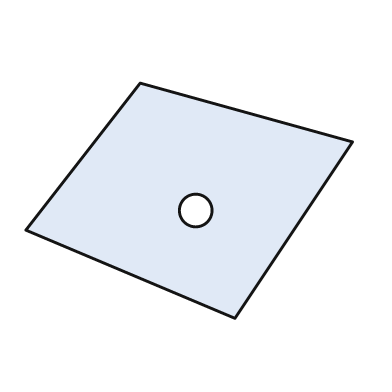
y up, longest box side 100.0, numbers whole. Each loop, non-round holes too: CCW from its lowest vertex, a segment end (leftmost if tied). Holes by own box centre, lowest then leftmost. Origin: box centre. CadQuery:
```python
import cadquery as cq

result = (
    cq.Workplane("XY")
    .moveTo(14.0, -36.0)
    .lineTo(50.0, 18.0)
    .lineTo(-15.0, 36.0)
    .lineTo(-50.0, -9.0)
    .close()
    .moveTo(2.0, -3.0)
    .circle(5.0)
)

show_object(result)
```